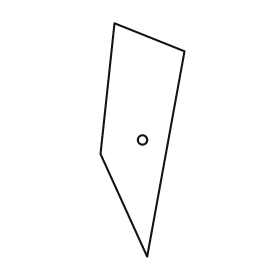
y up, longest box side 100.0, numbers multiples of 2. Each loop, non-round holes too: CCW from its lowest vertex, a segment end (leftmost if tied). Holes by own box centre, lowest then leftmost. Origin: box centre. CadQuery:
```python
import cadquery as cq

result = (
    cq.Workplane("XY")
    .moveTo(2.0, -50.0)
    .lineTo(18.0, 38.0)
    .lineTo(-12.0, 50.0)
    .lineTo(-18.0, -6.0)
    .close()
    .moveTo(0.0, 0.0)
    .circle(2.0)
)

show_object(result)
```